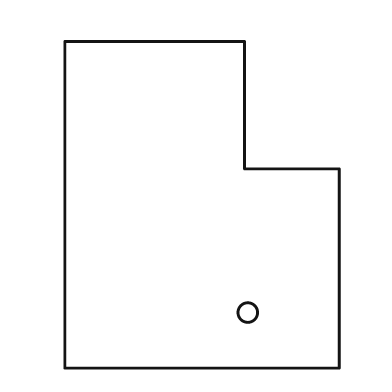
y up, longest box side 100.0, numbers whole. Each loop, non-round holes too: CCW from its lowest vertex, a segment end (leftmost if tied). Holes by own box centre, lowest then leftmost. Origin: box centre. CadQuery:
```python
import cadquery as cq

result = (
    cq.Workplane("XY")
    .moveTo(-42.0, -50.0)
    .lineTo(42.0, -50.0)
    .lineTo(42.0, 11.0)
    .lineTo(13.0, 11.0)
    .lineTo(13.0, 50.0)
    .lineTo(-42.0, 50.0)
    .close()
    .moveTo(14.0, -33.0)
    .circle(3.0)
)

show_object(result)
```